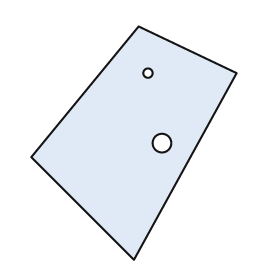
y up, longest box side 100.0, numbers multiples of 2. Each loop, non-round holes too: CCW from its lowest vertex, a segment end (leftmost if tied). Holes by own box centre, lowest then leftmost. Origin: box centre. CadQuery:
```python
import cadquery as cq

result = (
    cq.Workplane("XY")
    .moveTo(0.0, -50.0)
    .lineTo(44.0, 30.0)
    .lineTo(2.0, 50.0)
    .lineTo(-44.0, -6.0)
    .close()
    .moveTo(12.0, 0.0)
    .circle(4.0)
    .moveTo(6.0, 30.0)
    .circle(2.0)
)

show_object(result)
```